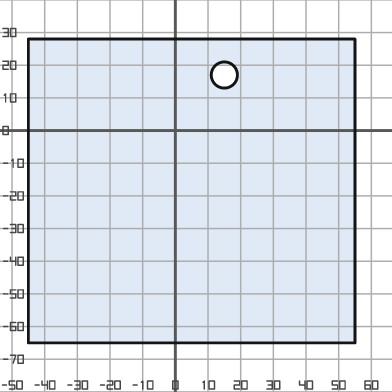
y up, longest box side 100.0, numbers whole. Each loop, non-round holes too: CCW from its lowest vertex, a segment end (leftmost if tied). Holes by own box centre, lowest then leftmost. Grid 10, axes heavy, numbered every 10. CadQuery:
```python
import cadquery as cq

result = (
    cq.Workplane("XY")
    .moveTo(-45.0, -65.0)
    .lineTo(55.0, -65.0)
    .lineTo(55.0, 28.0)
    .lineTo(-45.0, 28.0)
    .close()
    .moveTo(15.0, 17.0)
    .circle(4.0)
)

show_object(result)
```